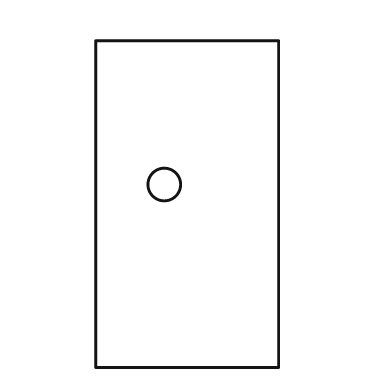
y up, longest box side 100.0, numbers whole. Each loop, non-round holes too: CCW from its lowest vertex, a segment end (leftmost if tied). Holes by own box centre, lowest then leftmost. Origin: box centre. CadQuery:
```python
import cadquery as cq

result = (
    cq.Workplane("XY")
    .moveTo(-28.0, -50.0)
    .lineTo(28.0, -50.0)
    .lineTo(28.0, 50.0)
    .lineTo(-28.0, 50.0)
    .close()
    .moveTo(-7.0, 6.0)
    .circle(5.0)
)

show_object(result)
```